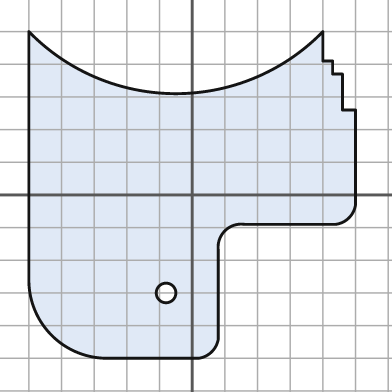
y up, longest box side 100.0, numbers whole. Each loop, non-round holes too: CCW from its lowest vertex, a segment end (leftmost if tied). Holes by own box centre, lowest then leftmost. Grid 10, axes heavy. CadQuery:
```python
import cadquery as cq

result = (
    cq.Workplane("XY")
    .moveTo(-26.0, -50.0)
    .lineTo(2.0, -50.0)
    .threePointArc((6.0, -48.0), (8.0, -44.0))
    .lineTo(8.0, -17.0)
    .threePointArc((10.0, -11.0), (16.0, -9.0))
    .lineTo(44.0, -9.0)
    .threePointArc((48.0, -7.0), (50.0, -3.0))
    .lineTo(50.0, 26.0)
    .lineTo(46.0, 26.0)
    .lineTo(46.0, 37.0)
    .lineTo(43.0, 37.0)
    .lineTo(43.0, 41.0)
    .lineTo(40.0, 41.0)
    .lineTo(40.0, 50.0)
    .threePointArc((-5.0, 31.0), (-50.0, 50.0))
    .lineTo(-50.0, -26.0)
    .threePointArc((-43.0, -43.0), (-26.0, -50.0))
    .close()
    .moveTo(-8.0, -30.0)
    .circle(3.0)
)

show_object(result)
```